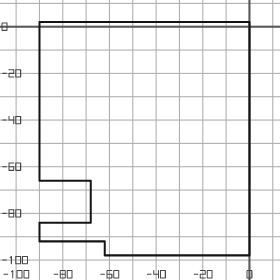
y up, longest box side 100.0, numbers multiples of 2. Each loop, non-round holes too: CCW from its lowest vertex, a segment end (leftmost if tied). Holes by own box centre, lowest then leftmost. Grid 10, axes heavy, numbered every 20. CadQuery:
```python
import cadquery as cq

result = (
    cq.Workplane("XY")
    .moveTo(-62.0, -98.0)
    .lineTo(0.0, -98.0)
    .lineTo(0.0, 2.0)
    .lineTo(-90.0, 2.0)
    .lineTo(-90.0, -66.0)
    .lineTo(-68.0, -66.0)
    .lineTo(-68.0, -84.0)
    .lineTo(-90.0, -84.0)
    .lineTo(-90.0, -92.0)
    .lineTo(-62.0, -92.0)
    .close()
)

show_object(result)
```